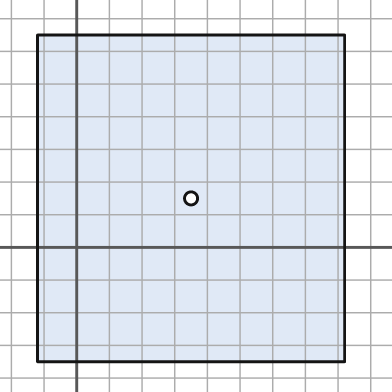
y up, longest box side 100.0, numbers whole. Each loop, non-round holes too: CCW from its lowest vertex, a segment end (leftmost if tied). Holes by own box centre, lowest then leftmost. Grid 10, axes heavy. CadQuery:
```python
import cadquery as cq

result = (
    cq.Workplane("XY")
    .moveTo(-12.0, -35.0)
    .lineTo(82.0, -35.0)
    .lineTo(82.0, 65.0)
    .lineTo(-12.0, 65.0)
    .close()
    .moveTo(35.0, 15.0)
    .circle(2.0)
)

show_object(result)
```